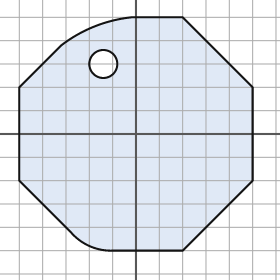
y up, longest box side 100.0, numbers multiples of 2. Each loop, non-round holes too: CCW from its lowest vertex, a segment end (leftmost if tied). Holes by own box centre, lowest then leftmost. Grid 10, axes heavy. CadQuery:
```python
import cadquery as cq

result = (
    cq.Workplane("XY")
    .moveTo(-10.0, -50.0)
    .lineTo(20.0, -50.0)
    .lineTo(50.0, -20.0)
    .lineTo(50.0, 20.0)
    .lineTo(20.0, 50.0)
    .lineTo(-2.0, 50.0)
    .threePointArc((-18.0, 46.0), (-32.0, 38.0))
    .lineTo(-50.0, 20.0)
    .lineTo(-50.0, -20.0)
    .lineTo(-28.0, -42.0)
    .threePointArc((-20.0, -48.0), (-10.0, -50.0))
    .close()
    .moveTo(-14.0, 30.0)
    .circle(6.0)
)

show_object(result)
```